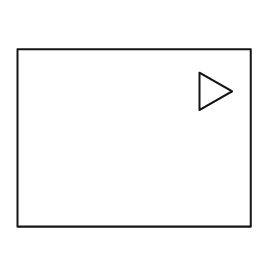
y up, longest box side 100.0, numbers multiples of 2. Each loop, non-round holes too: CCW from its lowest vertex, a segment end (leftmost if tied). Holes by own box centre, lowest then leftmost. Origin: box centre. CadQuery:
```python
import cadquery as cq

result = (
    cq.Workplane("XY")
    .moveTo(-50.0, -38.0)
    .lineTo(50.0, -38.0)
    .lineTo(50.0, 38.0)
    .lineTo(-50.0, 38.0)
    .close()
    .moveTo(28.0, 12.0)
    .lineTo(42.0, 20.0)
    .lineTo(28.0, 28.0)
    .close()
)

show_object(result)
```